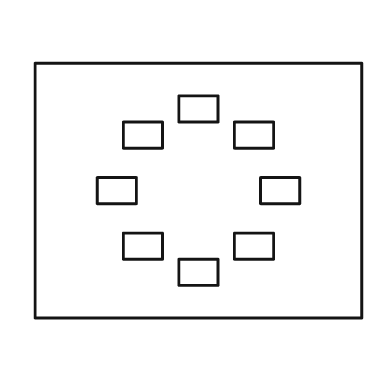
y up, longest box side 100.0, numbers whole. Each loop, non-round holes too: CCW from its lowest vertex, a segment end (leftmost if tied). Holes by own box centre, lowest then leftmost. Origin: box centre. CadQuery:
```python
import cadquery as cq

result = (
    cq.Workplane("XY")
    .moveTo(-50.0, -39.0)
    .lineTo(50.0, -39.0)
    .lineTo(50.0, 39.0)
    .lineTo(-50.0, 39.0)
    .close()
    .moveTo(-6.0, -29.0)
    .lineTo(6.0, -29.0)
    .lineTo(6.0, -21.0)
    .lineTo(-6.0, -21.0)
    .close()
    .moveTo(-23.0, -21.0)
    .lineTo(-11.0, -21.0)
    .lineTo(-11.0, -13.0)
    .lineTo(-23.0, -13.0)
    .close()
    .moveTo(11.0, -21.0)
    .lineTo(23.0, -21.0)
    .lineTo(23.0, -13.0)
    .lineTo(11.0, -13.0)
    .close()
    .moveTo(-31.0, -4.0)
    .lineTo(-19.0, -4.0)
    .lineTo(-19.0, 4.0)
    .lineTo(-31.0, 4.0)
    .close()
    .moveTo(19.0, -4.0)
    .lineTo(31.0, -4.0)
    .lineTo(31.0, 4.0)
    .lineTo(19.0, 4.0)
    .close()
    .moveTo(-23.0, 13.0)
    .lineTo(-11.0, 13.0)
    .lineTo(-11.0, 21.0)
    .lineTo(-23.0, 21.0)
    .close()
    .moveTo(11.0, 13.0)
    .lineTo(23.0, 13.0)
    .lineTo(23.0, 21.0)
    .lineTo(11.0, 21.0)
    .close()
    .moveTo(-6.0, 21.0)
    .lineTo(6.0, 21.0)
    .lineTo(6.0, 29.0)
    .lineTo(-6.0, 29.0)
    .close()
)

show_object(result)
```